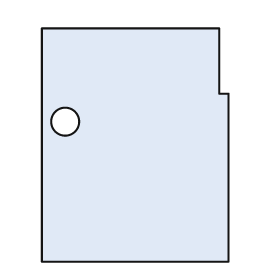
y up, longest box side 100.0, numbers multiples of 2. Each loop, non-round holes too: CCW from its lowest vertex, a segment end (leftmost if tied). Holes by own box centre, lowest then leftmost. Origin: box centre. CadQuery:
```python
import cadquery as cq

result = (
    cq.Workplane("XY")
    .moveTo(-40.0, -50.0)
    .lineTo(40.0, -50.0)
    .lineTo(40.0, 22.0)
    .lineTo(36.0, 22.0)
    .lineTo(36.0, 50.0)
    .lineTo(-40.0, 50.0)
    .close()
    .moveTo(-30.0, 10.0)
    .circle(6.0)
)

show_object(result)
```